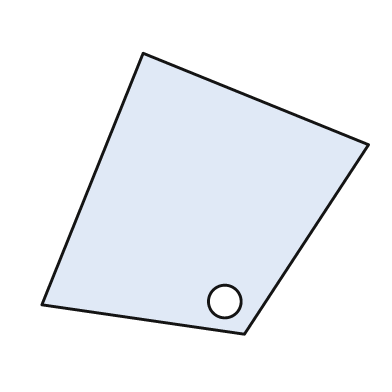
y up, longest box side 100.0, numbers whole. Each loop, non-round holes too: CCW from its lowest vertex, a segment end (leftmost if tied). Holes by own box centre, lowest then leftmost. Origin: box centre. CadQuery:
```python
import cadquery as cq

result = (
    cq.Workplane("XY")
    .moveTo(12.0, -43.0)
    .lineTo(50.0, 15.0)
    .lineTo(-19.0, 43.0)
    .lineTo(-50.0, -34.0)
    .close()
    .moveTo(6.0, -33.0)
    .circle(5.0)
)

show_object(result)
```